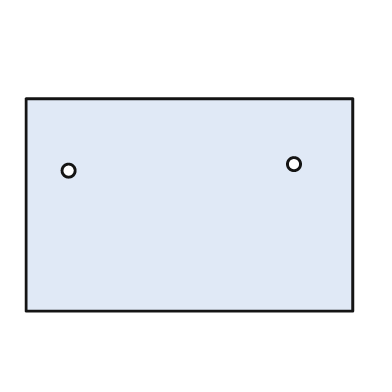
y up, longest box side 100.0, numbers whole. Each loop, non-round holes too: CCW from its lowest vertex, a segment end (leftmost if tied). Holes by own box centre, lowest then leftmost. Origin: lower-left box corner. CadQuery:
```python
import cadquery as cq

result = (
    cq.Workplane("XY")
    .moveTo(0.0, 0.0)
    .lineTo(100.0, 0.0)
    .lineTo(100.0, 65.0)
    .lineTo(0.0, 65.0)
    .close()
    .moveTo(13.0, 43.0)
    .circle(2.0)
    .moveTo(82.0, 45.0)
    .circle(2.0)
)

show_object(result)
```